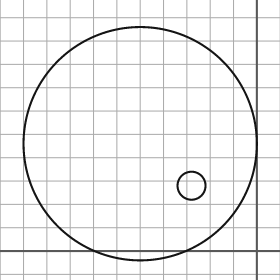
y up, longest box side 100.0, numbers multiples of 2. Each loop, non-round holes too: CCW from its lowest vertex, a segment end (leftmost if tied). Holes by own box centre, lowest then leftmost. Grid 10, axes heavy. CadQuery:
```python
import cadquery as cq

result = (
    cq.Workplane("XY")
    .moveTo(-50.0, 46.0)
    .circle(50.0)
    .moveTo(-28.0, 28.0)
    .circle(6.0)
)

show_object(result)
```